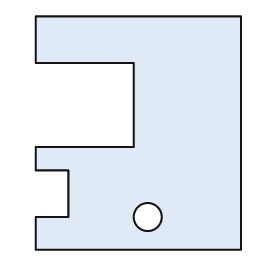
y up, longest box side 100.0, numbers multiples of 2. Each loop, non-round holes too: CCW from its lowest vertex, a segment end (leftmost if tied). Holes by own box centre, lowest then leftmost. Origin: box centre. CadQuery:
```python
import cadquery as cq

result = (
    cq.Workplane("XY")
    .moveTo(-44.0, -50.0)
    .lineTo(44.0, -50.0)
    .lineTo(44.0, 50.0)
    .lineTo(-44.0, 50.0)
    .lineTo(-44.0, 30.0)
    .lineTo(-2.0, 30.0)
    .lineTo(-2.0, -6.0)
    .lineTo(-44.0, -6.0)
    .lineTo(-44.0, -16.0)
    .lineTo(-30.0, -16.0)
    .lineTo(-30.0, -36.0)
    .lineTo(-44.0, -36.0)
    .close()
    .moveTo(4.0, -36.0)
    .circle(6.0)
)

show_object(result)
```